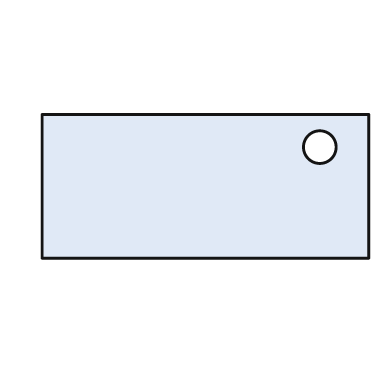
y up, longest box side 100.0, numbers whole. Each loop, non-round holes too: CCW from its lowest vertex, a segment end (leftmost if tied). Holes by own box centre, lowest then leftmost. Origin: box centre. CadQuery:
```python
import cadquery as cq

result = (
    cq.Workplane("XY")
    .moveTo(-50.0, -22.0)
    .lineTo(50.0, -22.0)
    .lineTo(50.0, 22.0)
    .lineTo(-50.0, 22.0)
    .close()
    .moveTo(35.0, 12.0)
    .circle(5.0)
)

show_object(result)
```